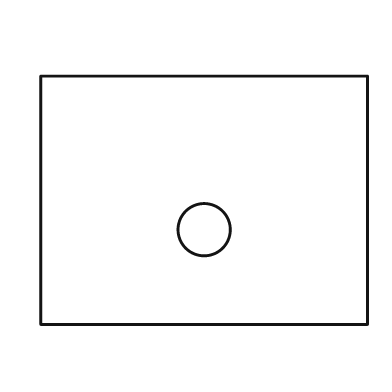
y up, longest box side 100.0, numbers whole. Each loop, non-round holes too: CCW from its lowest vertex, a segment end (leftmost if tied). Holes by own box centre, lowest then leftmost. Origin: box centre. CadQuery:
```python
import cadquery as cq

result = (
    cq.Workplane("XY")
    .moveTo(-50.0, -38.0)
    .lineTo(50.0, -38.0)
    .lineTo(50.0, 38.0)
    .lineTo(-50.0, 38.0)
    .close()
    .moveTo(0.0, -9.0)
    .circle(8.0)
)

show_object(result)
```